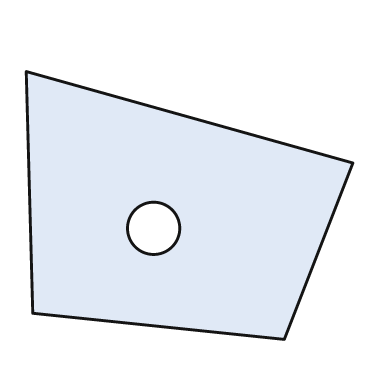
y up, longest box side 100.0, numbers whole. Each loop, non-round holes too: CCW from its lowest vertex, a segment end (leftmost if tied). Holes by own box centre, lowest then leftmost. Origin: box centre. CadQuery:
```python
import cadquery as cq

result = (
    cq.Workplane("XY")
    .moveTo(29.0, -41.0)
    .lineTo(50.0, 13.0)
    .lineTo(-50.0, 41.0)
    .lineTo(-48.0, -33.0)
    .close()
    .moveTo(-11.0, -7.0)
    .circle(8.0)
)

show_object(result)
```